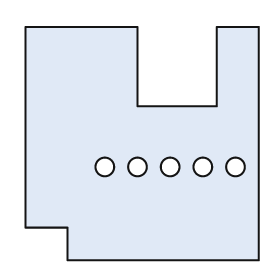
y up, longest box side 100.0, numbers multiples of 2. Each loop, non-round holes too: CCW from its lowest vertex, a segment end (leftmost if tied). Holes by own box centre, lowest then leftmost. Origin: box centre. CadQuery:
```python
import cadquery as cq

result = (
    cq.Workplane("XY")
    .moveTo(-32.0, -50.0)
    .lineTo(50.0, -50.0)
    .lineTo(50.0, 50.0)
    .lineTo(32.0, 50.0)
    .lineTo(32.0, 16.0)
    .lineTo(-2.0, 16.0)
    .lineTo(-2.0, 50.0)
    .lineTo(-50.0, 50.0)
    .lineTo(-50.0, -36.0)
    .lineTo(-32.0, -36.0)
    .close()
    .moveTo(-16.0, -10.0)
    .circle(4.0)
    .moveTo(-2.0, -10.0)
    .circle(4.0)
    .moveTo(12.0, -10.0)
    .circle(4.0)
    .moveTo(26.0, -10.0)
    .circle(4.0)
    .moveTo(40.0, -10.0)
    .circle(4.0)
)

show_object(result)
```